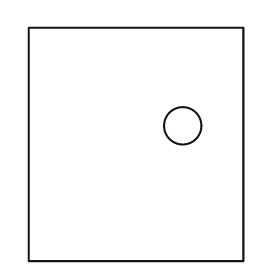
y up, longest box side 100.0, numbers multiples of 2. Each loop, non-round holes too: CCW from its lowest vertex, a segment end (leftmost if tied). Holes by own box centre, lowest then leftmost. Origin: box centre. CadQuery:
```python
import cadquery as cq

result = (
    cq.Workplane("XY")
    .moveTo(-46.0, -50.0)
    .lineTo(46.0, -50.0)
    .lineTo(46.0, 50.0)
    .lineTo(-46.0, 50.0)
    .close()
    .moveTo(20.0, 8.0)
    .circle(8.0)
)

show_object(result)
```